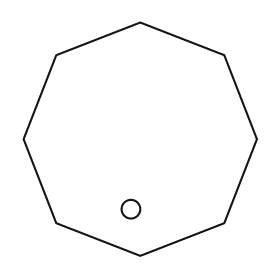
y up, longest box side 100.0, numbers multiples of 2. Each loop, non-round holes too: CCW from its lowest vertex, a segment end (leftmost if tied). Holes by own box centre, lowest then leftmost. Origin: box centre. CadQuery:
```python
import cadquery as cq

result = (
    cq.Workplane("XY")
    .moveTo(0.0, -50.0)
    .lineTo(36.0, -36.0)
    .lineTo(50.0, 0.0)
    .lineTo(36.0, 36.0)
    .lineTo(0.0, 50.0)
    .lineTo(-36.0, 36.0)
    .lineTo(-50.0, 0.0)
    .lineTo(-36.0, -36.0)
    .close()
    .moveTo(-4.0, -30.0)
    .circle(4.0)
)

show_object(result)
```